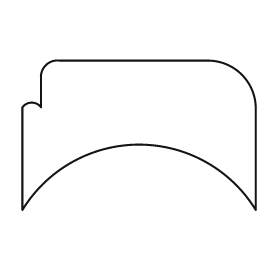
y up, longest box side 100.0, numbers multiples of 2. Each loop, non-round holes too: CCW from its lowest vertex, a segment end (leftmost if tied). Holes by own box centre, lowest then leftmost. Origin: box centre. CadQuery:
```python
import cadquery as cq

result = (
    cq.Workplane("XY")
    .moveTo(-50.0, -32.0)
    .threePointArc((0.0, -4.0), (50.0, -32.0))
    .lineTo(50.0, 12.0)
    .threePointArc((44.0, 26.0), (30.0, 32.0))
    .lineTo(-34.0, 32.0)
    .threePointArc((-40.0, 30.0), (-42.0, 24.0))
    .lineTo(-42.0, 12.0)
    .threePointArc((-46.0, 14.0), (-50.0, 12.0))
    .close()
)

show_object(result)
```